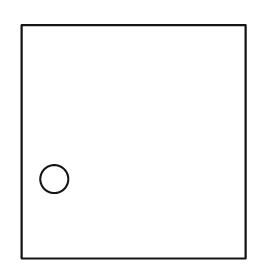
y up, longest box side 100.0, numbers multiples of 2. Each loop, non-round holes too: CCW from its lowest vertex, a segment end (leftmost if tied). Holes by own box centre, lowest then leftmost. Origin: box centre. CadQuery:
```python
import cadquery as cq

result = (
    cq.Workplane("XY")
    .moveTo(-48.0, -50.0)
    .lineTo(48.0, -50.0)
    .lineTo(48.0, 50.0)
    .lineTo(-48.0, 50.0)
    .close()
    .moveTo(-34.0, -16.0)
    .circle(6.0)
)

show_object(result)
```